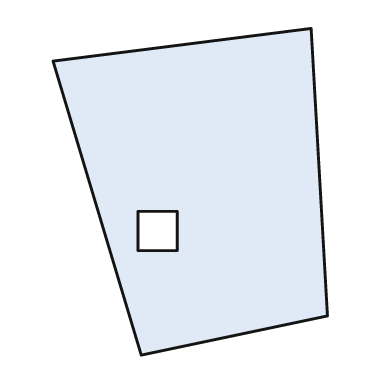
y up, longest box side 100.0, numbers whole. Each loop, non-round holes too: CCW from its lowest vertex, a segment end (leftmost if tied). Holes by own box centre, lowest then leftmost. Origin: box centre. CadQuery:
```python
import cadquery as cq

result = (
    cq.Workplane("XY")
    .moveTo(-15.0, -50.0)
    .lineTo(42.0, -38.0)
    .lineTo(37.0, 50.0)
    .lineTo(-42.0, 40.0)
    .close()
    .moveTo(-16.0, -18.0)
    .lineTo(-4.0, -18.0)
    .lineTo(-4.0, -6.0)
    .lineTo(-16.0, -6.0)
    .close()
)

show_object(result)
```